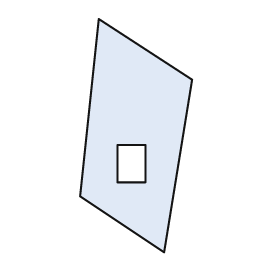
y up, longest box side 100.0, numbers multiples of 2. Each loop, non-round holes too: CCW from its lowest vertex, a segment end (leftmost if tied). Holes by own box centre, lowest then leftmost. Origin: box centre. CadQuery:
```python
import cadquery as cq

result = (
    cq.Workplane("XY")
    .moveTo(12.0, -50.0)
    .lineTo(24.0, 24.0)
    .lineTo(-16.0, 50.0)
    .lineTo(-24.0, -26.0)
    .close()
    .moveTo(-8.0, -20.0)
    .lineTo(4.0, -20.0)
    .lineTo(4.0, -4.0)
    .lineTo(-8.0, -4.0)
    .close()
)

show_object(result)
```